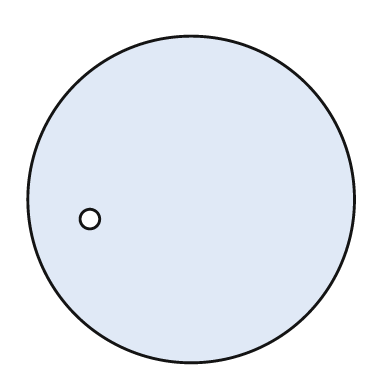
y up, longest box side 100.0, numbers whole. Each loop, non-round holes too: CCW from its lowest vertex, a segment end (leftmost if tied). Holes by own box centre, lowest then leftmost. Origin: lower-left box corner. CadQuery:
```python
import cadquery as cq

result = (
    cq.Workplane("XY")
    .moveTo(50.0, 50.0)
    .circle(50.0)
    .moveTo(19.0, 44.0)
    .circle(3.0)
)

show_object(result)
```